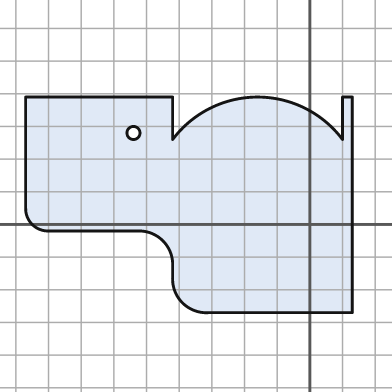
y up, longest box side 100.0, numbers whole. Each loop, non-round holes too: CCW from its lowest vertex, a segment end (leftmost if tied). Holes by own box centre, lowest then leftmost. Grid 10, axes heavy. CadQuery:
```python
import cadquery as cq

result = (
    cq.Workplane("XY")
    .moveTo(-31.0, -27.0)
    .lineTo(13.0, -27.0)
    .lineTo(13.0, 39.0)
    .lineTo(10.0, 39.0)
    .lineTo(10.0, 26.0)
    .threePointArc((-16.0, 39.0), (-42.0, 26.0))
    .lineTo(-42.0, 39.0)
    .lineTo(-87.0, 39.0)
    .lineTo(-87.0, 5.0)
    .threePointArc((-85.0, 0.0), (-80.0, -2.0))
    .lineTo(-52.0, -2.0)
    .threePointArc((-45.0, -5.0), (-42.0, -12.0))
    .lineTo(-42.0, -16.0)
    .threePointArc((-39.0, -24.0), (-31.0, -27.0))
    .close()
    .moveTo(-54.0, 28.0)
    .circle(2.0)
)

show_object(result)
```